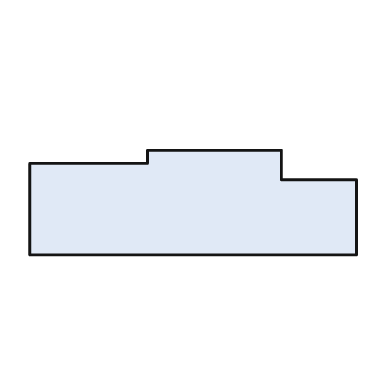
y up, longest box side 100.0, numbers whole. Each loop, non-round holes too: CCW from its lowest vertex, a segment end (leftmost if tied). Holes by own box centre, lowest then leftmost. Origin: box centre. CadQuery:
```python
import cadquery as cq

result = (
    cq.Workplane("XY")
    .moveTo(-50.0, -16.0)
    .lineTo(50.0, -16.0)
    .lineTo(50.0, 7.0)
    .lineTo(27.0, 7.0)
    .lineTo(27.0, 16.0)
    .lineTo(-14.0, 16.0)
    .lineTo(-14.0, 12.0)
    .lineTo(-50.0, 12.0)
    .close()
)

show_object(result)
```